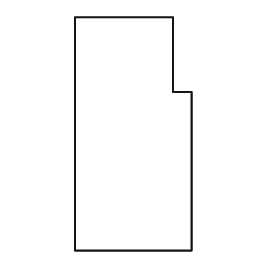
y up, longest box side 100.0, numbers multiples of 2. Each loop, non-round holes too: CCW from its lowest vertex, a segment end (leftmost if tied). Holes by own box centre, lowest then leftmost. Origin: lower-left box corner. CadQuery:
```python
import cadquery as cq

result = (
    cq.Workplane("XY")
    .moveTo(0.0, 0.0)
    .lineTo(50.0, 0.0)
    .lineTo(50.0, 68.0)
    .lineTo(42.0, 68.0)
    .lineTo(42.0, 100.0)
    .lineTo(0.0, 100.0)
    .close()
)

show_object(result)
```